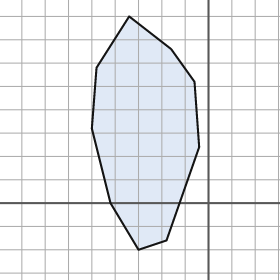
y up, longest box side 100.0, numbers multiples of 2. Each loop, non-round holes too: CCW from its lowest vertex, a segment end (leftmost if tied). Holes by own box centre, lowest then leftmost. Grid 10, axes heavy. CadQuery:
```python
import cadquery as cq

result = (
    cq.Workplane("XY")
    .moveTo(-30.0, -20.0)
    .lineTo(-18.0, -16.0)
    .lineTo(-4.0, 24.0)
    .lineTo(-6.0, 52.0)
    .lineTo(-16.0, 66.0)
    .lineTo(-34.0, 80.0)
    .lineTo(-48.0, 58.0)
    .lineTo(-50.0, 32.0)
    .lineTo(-42.0, 0.0)
    .close()
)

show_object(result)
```